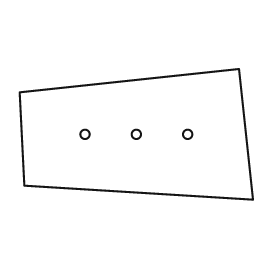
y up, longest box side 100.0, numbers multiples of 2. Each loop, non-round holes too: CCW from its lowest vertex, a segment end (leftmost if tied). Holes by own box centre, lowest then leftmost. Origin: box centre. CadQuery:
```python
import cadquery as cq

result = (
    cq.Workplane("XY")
    .moveTo(50.0, -28.0)
    .lineTo(44.0, 28.0)
    .lineTo(-50.0, 18.0)
    .lineTo(-48.0, -22.0)
    .close()
    .moveTo(-22.0, 0.0)
    .circle(2.0)
    .moveTo(0.0, 0.0)
    .circle(2.0)
    .moveTo(22.0, 0.0)
    .circle(2.0)
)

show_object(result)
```